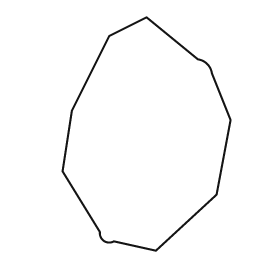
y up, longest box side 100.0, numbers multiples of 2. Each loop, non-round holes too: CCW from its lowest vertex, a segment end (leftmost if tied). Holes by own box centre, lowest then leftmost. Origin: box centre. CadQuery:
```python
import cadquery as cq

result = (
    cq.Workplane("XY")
    .moveTo(4.0, -50.0)
    .lineTo(30.0, -26.0)
    .lineTo(36.0, 6.0)
    .lineTo(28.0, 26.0)
    .threePointArc((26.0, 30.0), (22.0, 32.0))
    .lineTo(0.0, 50.0)
    .lineTo(-16.0, 42.0)
    .lineTo(-32.0, 10.0)
    .lineTo(-36.0, -16.0)
    .lineTo(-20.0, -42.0)
    .threePointArc((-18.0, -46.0), (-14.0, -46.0))
    .close()
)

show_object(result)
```